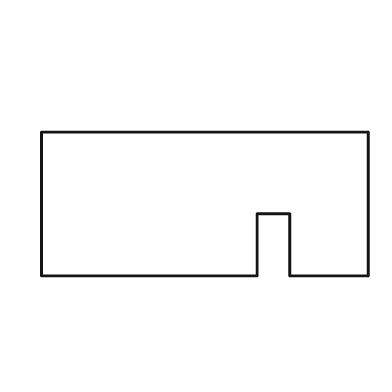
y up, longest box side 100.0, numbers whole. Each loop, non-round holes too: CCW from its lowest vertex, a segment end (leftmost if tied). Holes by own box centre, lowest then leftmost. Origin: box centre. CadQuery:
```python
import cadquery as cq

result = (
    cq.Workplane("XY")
    .moveTo(-50.0, -22.0)
    .lineTo(16.0, -22.0)
    .lineTo(16.0, -3.0)
    .lineTo(26.0, -3.0)
    .lineTo(26.0, -22.0)
    .lineTo(50.0, -22.0)
    .lineTo(50.0, 22.0)
    .lineTo(-50.0, 22.0)
    .close()
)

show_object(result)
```